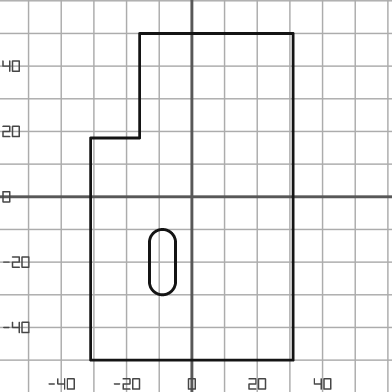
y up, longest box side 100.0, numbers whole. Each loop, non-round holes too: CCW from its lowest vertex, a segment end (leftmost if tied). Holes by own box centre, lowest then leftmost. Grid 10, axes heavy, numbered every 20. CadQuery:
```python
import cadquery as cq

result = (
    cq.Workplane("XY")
    .moveTo(-31.0, -50.0)
    .lineTo(31.0, -50.0)
    .lineTo(31.0, 50.0)
    .lineTo(-16.0, 50.0)
    .lineTo(-16.0, 18.0)
    .lineTo(-31.0, 18.0)
    .close()
    .moveTo(-13.0, -26.0)
    .threePointArc((-9.0, -30.0), (-5.0, -26.0))
    .lineTo(-5.0, -14.0)
    .threePointArc((-9.0, -10.0), (-13.0, -14.0))
    .close()
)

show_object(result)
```